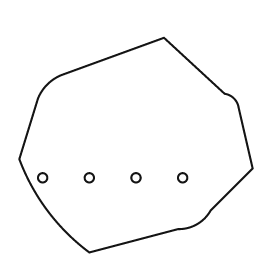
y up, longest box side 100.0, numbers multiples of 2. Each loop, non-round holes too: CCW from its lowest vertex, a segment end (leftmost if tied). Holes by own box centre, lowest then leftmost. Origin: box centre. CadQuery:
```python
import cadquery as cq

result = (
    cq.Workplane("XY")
    .moveTo(-20.0, -46.0)
    .lineTo(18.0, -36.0)
    .threePointArc((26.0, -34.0), (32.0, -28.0))
    .lineTo(50.0, -10.0)
    .lineTo(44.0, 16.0)
    .threePointArc((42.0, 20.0), (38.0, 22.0))
    .lineTo(12.0, 46.0)
    .lineTo(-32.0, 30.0)
    .threePointArc((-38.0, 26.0), (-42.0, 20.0))
    .lineTo(-50.0, -6.0)
    .threePointArc((-38.0, -28.0), (-20.0, -46.0))
    .close()
    .moveTo(-40.0, -14.0)
    .circle(2.0)
    .moveTo(-20.0, -14.0)
    .circle(2.0)
    .moveTo(0.0, -14.0)
    .circle(2.0)
    .moveTo(20.0, -14.0)
    .circle(2.0)
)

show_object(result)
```